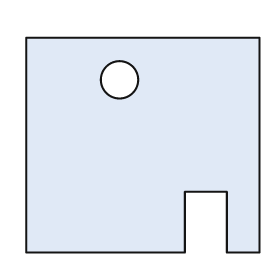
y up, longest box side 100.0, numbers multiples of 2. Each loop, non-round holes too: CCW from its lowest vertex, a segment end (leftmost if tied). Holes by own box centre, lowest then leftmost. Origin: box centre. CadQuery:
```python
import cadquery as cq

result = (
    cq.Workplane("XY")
    .moveTo(-50.0, -46.0)
    .lineTo(18.0, -46.0)
    .lineTo(18.0, -20.0)
    .lineTo(36.0, -20.0)
    .lineTo(36.0, -46.0)
    .lineTo(50.0, -46.0)
    .lineTo(50.0, 46.0)
    .lineTo(-50.0, 46.0)
    .close()
    .moveTo(-10.0, 28.0)
    .circle(8.0)
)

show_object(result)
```